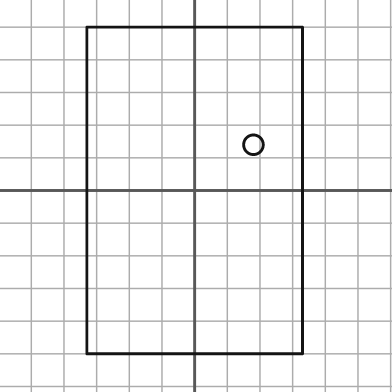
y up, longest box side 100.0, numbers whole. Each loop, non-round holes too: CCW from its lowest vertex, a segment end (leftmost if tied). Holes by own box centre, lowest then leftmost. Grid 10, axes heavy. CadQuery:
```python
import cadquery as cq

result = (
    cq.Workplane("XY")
    .moveTo(-33.0, -50.0)
    .lineTo(33.0, -50.0)
    .lineTo(33.0, 50.0)
    .lineTo(-33.0, 50.0)
    .close()
    .moveTo(18.0, 14.0)
    .circle(3.0)
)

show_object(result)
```